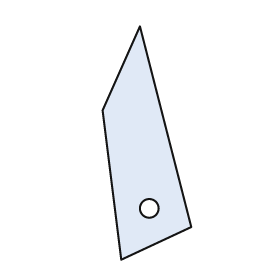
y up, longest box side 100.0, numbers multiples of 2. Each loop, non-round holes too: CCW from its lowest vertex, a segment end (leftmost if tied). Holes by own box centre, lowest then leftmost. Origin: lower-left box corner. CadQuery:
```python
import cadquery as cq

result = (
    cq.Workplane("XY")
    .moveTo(8.0, 0.0)
    .lineTo(38.0, 14.0)
    .lineTo(16.0, 100.0)
    .lineTo(0.0, 64.0)
    .close()
    .moveTo(20.0, 22.0)
    .circle(4.0)
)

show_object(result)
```